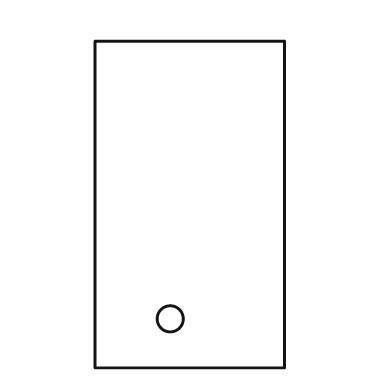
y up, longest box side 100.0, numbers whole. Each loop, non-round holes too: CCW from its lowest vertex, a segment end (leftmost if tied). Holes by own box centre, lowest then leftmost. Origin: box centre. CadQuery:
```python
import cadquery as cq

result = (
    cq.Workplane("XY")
    .moveTo(-29.0, -50.0)
    .lineTo(29.0, -50.0)
    .lineTo(29.0, 50.0)
    .lineTo(-29.0, 50.0)
    .close()
    .moveTo(-6.0, -35.0)
    .circle(4.0)
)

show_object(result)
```